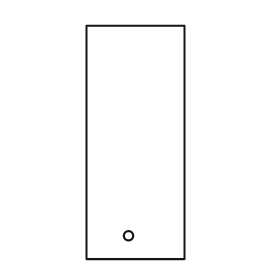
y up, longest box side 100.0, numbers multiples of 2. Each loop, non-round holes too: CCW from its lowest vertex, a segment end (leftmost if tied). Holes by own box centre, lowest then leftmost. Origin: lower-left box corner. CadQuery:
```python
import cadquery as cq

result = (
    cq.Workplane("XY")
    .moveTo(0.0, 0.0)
    .lineTo(42.0, 0.0)
    .lineTo(42.0, 100.0)
    .lineTo(0.0, 100.0)
    .close()
    .moveTo(18.0, 10.0)
    .circle(2.0)
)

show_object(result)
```